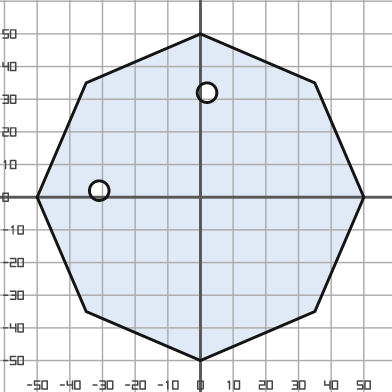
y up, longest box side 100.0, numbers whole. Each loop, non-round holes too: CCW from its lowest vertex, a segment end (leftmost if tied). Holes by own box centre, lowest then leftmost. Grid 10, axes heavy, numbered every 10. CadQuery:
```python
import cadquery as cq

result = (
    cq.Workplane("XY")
    .moveTo(0.0, -50.0)
    .lineTo(35.0, -35.0)
    .lineTo(50.0, 0.0)
    .lineTo(35.0, 35.0)
    .lineTo(0.0, 50.0)
    .lineTo(-35.0, 35.0)
    .lineTo(-50.0, 0.0)
    .lineTo(-35.0, -35.0)
    .close()
    .moveTo(-31.0, 2.0)
    .circle(3.0)
    .moveTo(2.0, 32.0)
    .circle(3.0)
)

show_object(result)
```